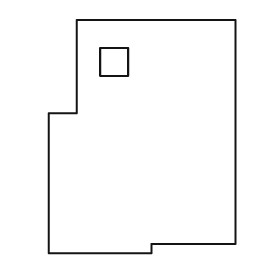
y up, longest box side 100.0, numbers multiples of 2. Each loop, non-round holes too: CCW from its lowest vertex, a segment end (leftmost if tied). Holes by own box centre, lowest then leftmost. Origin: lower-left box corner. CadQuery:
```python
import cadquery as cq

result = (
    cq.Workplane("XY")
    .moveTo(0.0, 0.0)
    .lineTo(44.0, 0.0)
    .lineTo(44.0, 4.0)
    .lineTo(80.0, 4.0)
    .lineTo(80.0, 100.0)
    .lineTo(12.0, 100.0)
    .lineTo(12.0, 60.0)
    .lineTo(0.0, 60.0)
    .close()
    .moveTo(22.0, 76.0)
    .lineTo(34.0, 76.0)
    .lineTo(34.0, 88.0)
    .lineTo(22.0, 88.0)
    .close()
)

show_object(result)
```